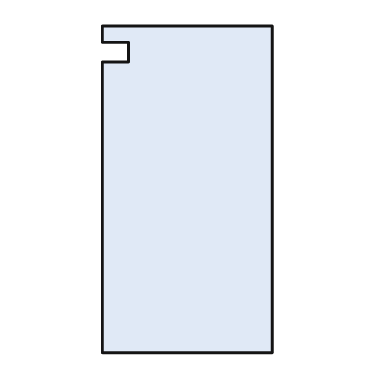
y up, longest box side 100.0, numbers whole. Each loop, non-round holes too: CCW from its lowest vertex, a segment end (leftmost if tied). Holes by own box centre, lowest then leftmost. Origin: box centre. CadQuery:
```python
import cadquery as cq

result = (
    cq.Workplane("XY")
    .moveTo(-26.0, -50.0)
    .lineTo(26.0, -50.0)
    .lineTo(26.0, 50.0)
    .lineTo(-26.0, 50.0)
    .lineTo(-26.0, 45.0)
    .lineTo(-18.0, 45.0)
    .lineTo(-18.0, 39.0)
    .lineTo(-26.0, 39.0)
    .close()
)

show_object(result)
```